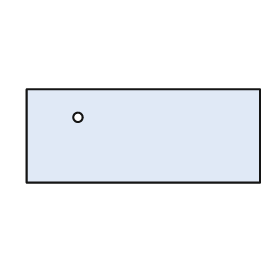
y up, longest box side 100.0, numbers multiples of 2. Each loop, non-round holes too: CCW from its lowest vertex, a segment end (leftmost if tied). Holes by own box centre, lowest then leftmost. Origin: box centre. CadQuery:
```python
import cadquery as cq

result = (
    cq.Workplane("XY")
    .moveTo(-50.0, -20.0)
    .lineTo(50.0, -20.0)
    .lineTo(50.0, 20.0)
    .lineTo(-50.0, 20.0)
    .close()
    .moveTo(-28.0, 8.0)
    .circle(2.0)
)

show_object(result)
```